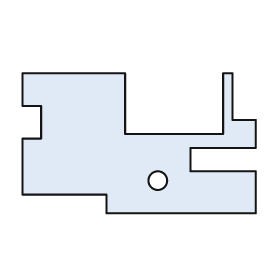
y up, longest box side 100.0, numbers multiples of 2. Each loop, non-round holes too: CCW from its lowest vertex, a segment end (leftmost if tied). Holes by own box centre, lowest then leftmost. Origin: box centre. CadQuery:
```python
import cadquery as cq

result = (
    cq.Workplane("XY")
    .moveTo(-14.0, -30.0)
    .lineTo(50.0, -30.0)
    .lineTo(50.0, -12.0)
    .lineTo(22.0, -12.0)
    .lineTo(22.0, -2.0)
    .lineTo(50.0, -2.0)
    .lineTo(50.0, 10.0)
    .lineTo(40.0, 10.0)
    .lineTo(40.0, 30.0)
    .lineTo(36.0, 30.0)
    .lineTo(36.0, 4.0)
    .lineTo(-6.0, 4.0)
    .lineTo(-6.0, 30.0)
    .lineTo(-50.0, 30.0)
    .lineTo(-50.0, 16.0)
    .lineTo(-42.0, 16.0)
    .lineTo(-42.0, 2.0)
    .lineTo(-50.0, 2.0)
    .lineTo(-50.0, -22.0)
    .lineTo(-14.0, -22.0)
    .close()
    .moveTo(8.0, -16.0)
    .circle(4.0)
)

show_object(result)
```